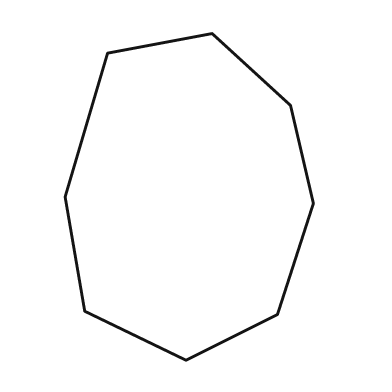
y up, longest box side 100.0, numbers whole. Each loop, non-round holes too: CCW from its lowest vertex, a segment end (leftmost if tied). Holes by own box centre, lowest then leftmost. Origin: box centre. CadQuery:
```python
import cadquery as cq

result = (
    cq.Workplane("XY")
    .moveTo(-1.0, -50.0)
    .lineTo(27.0, -36.0)
    .lineTo(38.0, -2.0)
    .lineTo(31.0, 28.0)
    .lineTo(7.0, 50.0)
    .lineTo(-25.0, 44.0)
    .lineTo(-38.0, 0.0)
    .lineTo(-32.0, -35.0)
    .close()
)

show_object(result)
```